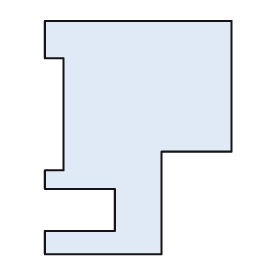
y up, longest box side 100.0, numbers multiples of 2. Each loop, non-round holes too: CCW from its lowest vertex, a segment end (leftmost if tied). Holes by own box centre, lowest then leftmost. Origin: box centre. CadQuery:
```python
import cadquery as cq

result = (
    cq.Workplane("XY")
    .moveTo(-40.0, -50.0)
    .lineTo(10.0, -50.0)
    .lineTo(10.0, -6.0)
    .lineTo(40.0, -6.0)
    .lineTo(40.0, 50.0)
    .lineTo(-40.0, 50.0)
    .lineTo(-40.0, 34.0)
    .lineTo(-32.0, 34.0)
    .lineTo(-32.0, -14.0)
    .lineTo(-40.0, -14.0)
    .lineTo(-40.0, -22.0)
    .lineTo(-10.0, -22.0)
    .lineTo(-10.0, -40.0)
    .lineTo(-40.0, -40.0)
    .close()
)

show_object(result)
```